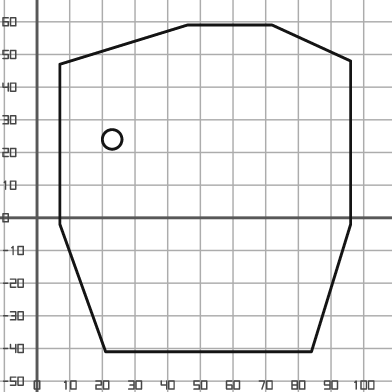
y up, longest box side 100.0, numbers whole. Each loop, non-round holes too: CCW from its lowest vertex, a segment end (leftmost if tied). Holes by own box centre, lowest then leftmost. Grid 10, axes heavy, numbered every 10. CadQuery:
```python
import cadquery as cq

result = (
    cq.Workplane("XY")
    .moveTo(21.0, -41.0)
    .lineTo(84.0, -41.0)
    .lineTo(96.0, -2.0)
    .lineTo(96.0, 48.0)
    .lineTo(72.0, 59.0)
    .lineTo(46.0, 59.0)
    .lineTo(7.0, 47.0)
    .lineTo(7.0, -2.0)
    .close()
    .moveTo(23.0, 24.0)
    .circle(3.0)
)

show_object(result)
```